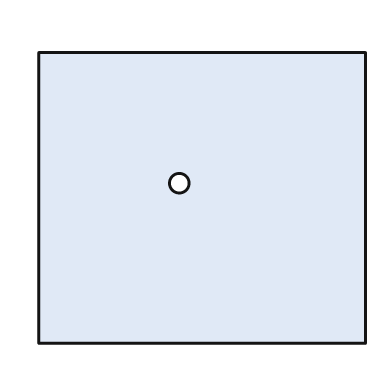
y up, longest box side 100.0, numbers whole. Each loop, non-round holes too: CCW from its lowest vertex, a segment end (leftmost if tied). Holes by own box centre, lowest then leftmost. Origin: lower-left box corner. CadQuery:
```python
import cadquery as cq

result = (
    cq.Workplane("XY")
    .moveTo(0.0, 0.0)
    .lineTo(100.0, 0.0)
    .lineTo(100.0, 89.0)
    .lineTo(0.0, 89.0)
    .close()
    .moveTo(43.0, 49.0)
    .circle(3.0)
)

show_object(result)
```